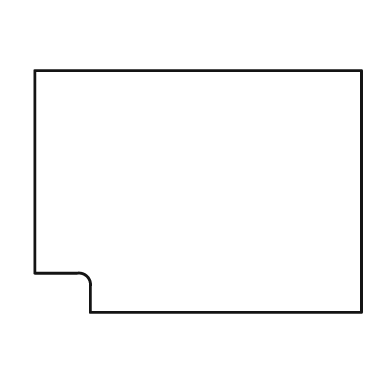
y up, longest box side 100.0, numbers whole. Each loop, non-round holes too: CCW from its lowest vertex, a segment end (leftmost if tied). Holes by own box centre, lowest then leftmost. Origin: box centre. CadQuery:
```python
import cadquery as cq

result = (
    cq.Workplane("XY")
    .moveTo(-33.0, -37.0)
    .lineTo(50.0, -37.0)
    .lineTo(50.0, 37.0)
    .lineTo(-50.0, 37.0)
    .lineTo(-50.0, -25.0)
    .lineTo(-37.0, -25.0)
    .threePointArc((-34.0, -26.0), (-33.0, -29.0))
    .close()
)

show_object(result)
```